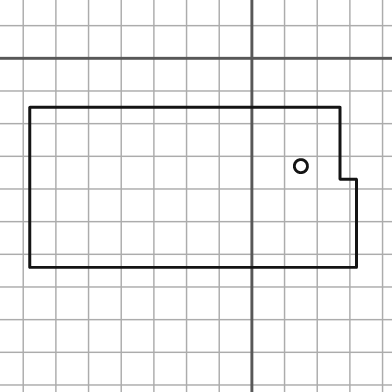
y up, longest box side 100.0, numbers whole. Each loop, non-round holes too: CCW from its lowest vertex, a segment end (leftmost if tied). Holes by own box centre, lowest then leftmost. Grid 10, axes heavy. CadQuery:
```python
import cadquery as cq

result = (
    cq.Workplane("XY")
    .moveTo(-68.0, -64.0)
    .lineTo(32.0, -64.0)
    .lineTo(32.0, -37.0)
    .lineTo(27.0, -37.0)
    .lineTo(27.0, -15.0)
    .lineTo(-68.0, -15.0)
    .close()
    .moveTo(15.0, -33.0)
    .circle(2.0)
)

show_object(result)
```